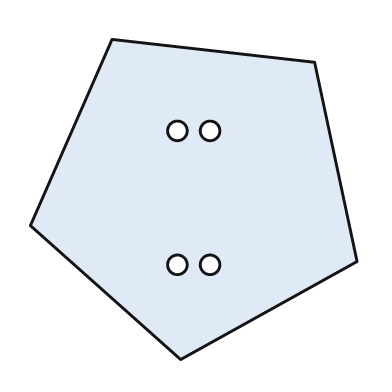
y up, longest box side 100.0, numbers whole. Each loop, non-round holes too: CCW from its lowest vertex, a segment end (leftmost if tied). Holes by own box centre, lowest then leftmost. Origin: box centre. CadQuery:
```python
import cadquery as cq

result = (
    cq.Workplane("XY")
    .moveTo(-4.0, -49.0)
    .lineTo(50.0, -19.0)
    .lineTo(37.0, 42.0)
    .lineTo(-25.0, 49.0)
    .lineTo(-50.0, -8.0)
    .close()
    .moveTo(-5.0, -20.0)
    .circle(3.0)
    .moveTo(5.0, -20.0)
    .circle(3.0)
    .moveTo(-5.0, 21.0)
    .circle(3.0)
    .moveTo(5.0, 21.0)
    .circle(3.0)
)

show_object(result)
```